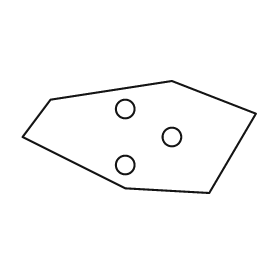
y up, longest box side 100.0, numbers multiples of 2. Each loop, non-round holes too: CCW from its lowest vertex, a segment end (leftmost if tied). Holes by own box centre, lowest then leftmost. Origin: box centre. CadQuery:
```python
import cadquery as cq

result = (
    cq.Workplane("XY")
    .moveTo(30.0, -24.0)
    .lineTo(50.0, 10.0)
    .lineTo(14.0, 24.0)
    .lineTo(-38.0, 16.0)
    .lineTo(-50.0, 0.0)
    .lineTo(-6.0, -22.0)
    .close()
    .moveTo(-6.0, -12.0)
    .circle(4.0)
    .moveTo(14.0, 0.0)
    .circle(4.0)
    .moveTo(-6.0, 12.0)
    .circle(4.0)
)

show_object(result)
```